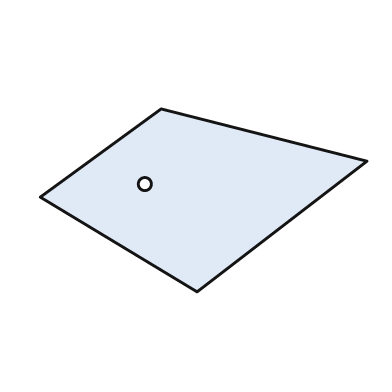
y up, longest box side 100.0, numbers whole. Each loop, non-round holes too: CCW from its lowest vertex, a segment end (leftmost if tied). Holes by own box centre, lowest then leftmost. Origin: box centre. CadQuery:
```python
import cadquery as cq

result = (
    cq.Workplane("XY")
    .moveTo(-2.0, -28.0)
    .lineTo(50.0, 12.0)
    .lineTo(-13.0, 28.0)
    .lineTo(-50.0, 1.0)
    .close()
    .moveTo(-18.0, 5.0)
    .circle(2.0)
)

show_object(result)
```